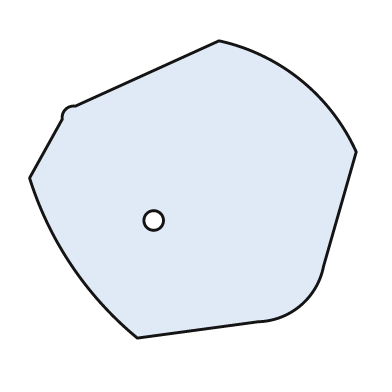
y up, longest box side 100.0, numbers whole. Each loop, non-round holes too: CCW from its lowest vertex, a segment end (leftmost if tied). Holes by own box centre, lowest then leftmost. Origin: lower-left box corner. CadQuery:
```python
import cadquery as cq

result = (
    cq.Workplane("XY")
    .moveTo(33.0, 0.0)
    .lineTo(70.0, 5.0)
    .threePointArc((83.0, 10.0), (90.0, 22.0))
    .lineTo(100.0, 57.0)
    .threePointArc((83.0, 79.0), (58.0, 91.0))
    .lineTo(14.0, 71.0)
    .threePointArc((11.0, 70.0), (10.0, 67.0))
    .lineTo(0.0, 49.0)
    .threePointArc((13.0, 22.0), (33.0, 0.0))
    .close()
    .moveTo(38.0, 36.0)
    .circle(3.0)
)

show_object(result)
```